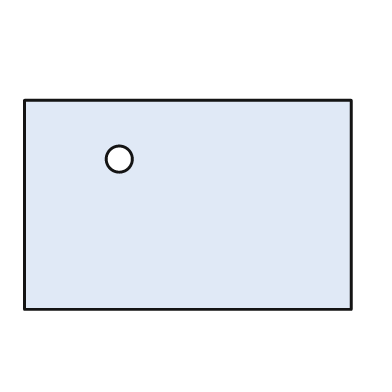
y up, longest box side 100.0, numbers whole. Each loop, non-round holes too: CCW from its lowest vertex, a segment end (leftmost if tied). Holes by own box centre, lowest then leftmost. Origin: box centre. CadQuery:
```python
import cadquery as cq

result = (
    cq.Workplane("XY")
    .moveTo(-50.0, -32.0)
    .lineTo(50.0, -32.0)
    .lineTo(50.0, 32.0)
    .lineTo(-50.0, 32.0)
    .close()
    .moveTo(-21.0, 14.0)
    .circle(4.0)
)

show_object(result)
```